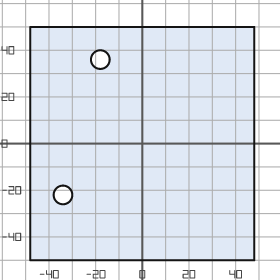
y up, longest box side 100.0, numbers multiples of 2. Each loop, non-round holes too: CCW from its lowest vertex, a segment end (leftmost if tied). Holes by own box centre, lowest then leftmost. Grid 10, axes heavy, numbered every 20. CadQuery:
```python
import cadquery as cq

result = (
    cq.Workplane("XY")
    .moveTo(-48.0, -50.0)
    .lineTo(48.0, -50.0)
    .lineTo(48.0, 50.0)
    .lineTo(-48.0, 50.0)
    .close()
    .moveTo(-34.0, -22.0)
    .circle(4.0)
    .moveTo(-18.0, 36.0)
    .circle(4.0)
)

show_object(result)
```